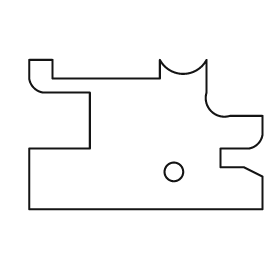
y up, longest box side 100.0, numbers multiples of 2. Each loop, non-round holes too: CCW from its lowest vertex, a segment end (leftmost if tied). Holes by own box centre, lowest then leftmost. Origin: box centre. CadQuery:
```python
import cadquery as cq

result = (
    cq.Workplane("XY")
    .moveTo(-50.0, -32.0)
    .lineTo(50.0, -32.0)
    .lineTo(50.0, -18.0)
    .lineTo(42.0, -14.0)
    .lineTo(32.0, -14.0)
    .lineTo(32.0, -6.0)
    .lineTo(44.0, -6.0)
    .threePointArc((48.0, -4.0), (50.0, 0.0))
    .lineTo(50.0, 8.0)
    .lineTo(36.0, 8.0)
    .threePointArc((28.0, 10.0), (26.0, 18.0))
    .lineTo(26.0, 32.0)
    .threePointArc((16.0, 26.0), (6.0, 32.0))
    .lineTo(6.0, 24.0)
    .lineTo(-40.0, 24.0)
    .lineTo(-40.0, 32.0)
    .lineTo(-50.0, 32.0)
    .lineTo(-50.0, 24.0)
    .threePointArc((-48.0, 20.0), (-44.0, 18.0))
    .lineTo(-24.0, 18.0)
    .lineTo(-24.0, -6.0)
    .lineTo(-50.0, -6.0)
    .close()
    .moveTo(12.0, -16.0)
    .circle(4.0)
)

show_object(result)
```